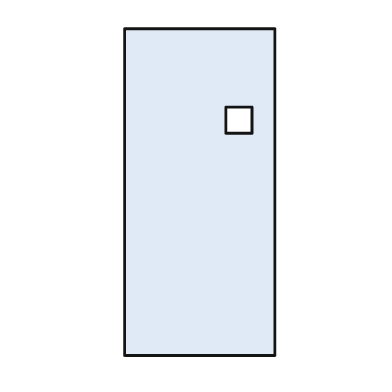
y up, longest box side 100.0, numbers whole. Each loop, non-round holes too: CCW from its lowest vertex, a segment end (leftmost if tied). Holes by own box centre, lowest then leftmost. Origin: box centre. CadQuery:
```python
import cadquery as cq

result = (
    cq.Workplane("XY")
    .moveTo(-23.0, -50.0)
    .lineTo(23.0, -50.0)
    .lineTo(23.0, 50.0)
    .lineTo(-23.0, 50.0)
    .close()
    .moveTo(8.0, 18.0)
    .lineTo(16.0, 18.0)
    .lineTo(16.0, 26.0)
    .lineTo(8.0, 26.0)
    .close()
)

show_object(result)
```